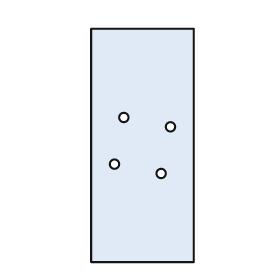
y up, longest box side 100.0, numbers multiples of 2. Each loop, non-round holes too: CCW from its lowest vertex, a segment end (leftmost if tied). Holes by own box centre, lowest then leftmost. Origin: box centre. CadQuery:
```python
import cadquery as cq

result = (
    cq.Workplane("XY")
    .moveTo(-22.0, -50.0)
    .lineTo(22.0, -50.0)
    .lineTo(22.0, 50.0)
    .lineTo(-22.0, 50.0)
    .close()
    .moveTo(8.0, -12.0)
    .circle(2.0)
    .moveTo(-12.0, -8.0)
    .circle(2.0)
    .moveTo(12.0, 8.0)
    .circle(2.0)
    .moveTo(-8.0, 12.0)
    .circle(2.0)
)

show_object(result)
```